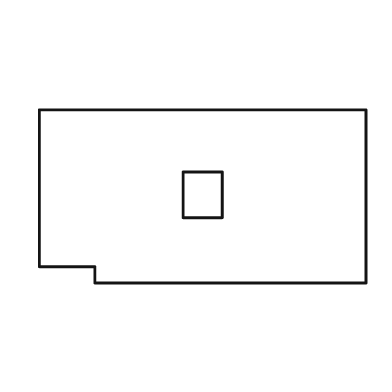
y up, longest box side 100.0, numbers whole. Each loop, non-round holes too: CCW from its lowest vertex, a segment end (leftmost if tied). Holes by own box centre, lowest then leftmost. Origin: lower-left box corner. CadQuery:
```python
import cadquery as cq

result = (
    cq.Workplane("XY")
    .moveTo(17.0, 0.0)
    .lineTo(100.0, 0.0)
    .lineTo(100.0, 53.0)
    .lineTo(0.0, 53.0)
    .lineTo(0.0, 5.0)
    .lineTo(17.0, 5.0)
    .close()
    .moveTo(44.0, 20.0)
    .lineTo(56.0, 20.0)
    .lineTo(56.0, 34.0)
    .lineTo(44.0, 34.0)
    .close()
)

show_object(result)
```